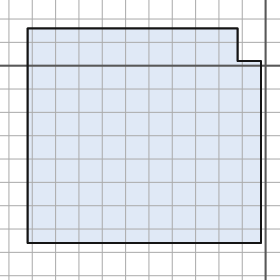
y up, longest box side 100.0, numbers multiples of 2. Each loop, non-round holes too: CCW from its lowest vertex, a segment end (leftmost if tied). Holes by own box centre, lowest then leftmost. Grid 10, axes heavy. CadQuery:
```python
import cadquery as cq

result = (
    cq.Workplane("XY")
    .moveTo(-102.0, -76.0)
    .lineTo(-2.0, -76.0)
    .lineTo(-2.0, 2.0)
    .lineTo(-12.0, 2.0)
    .lineTo(-12.0, 16.0)
    .lineTo(-102.0, 16.0)
    .close()
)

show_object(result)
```